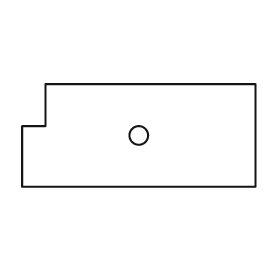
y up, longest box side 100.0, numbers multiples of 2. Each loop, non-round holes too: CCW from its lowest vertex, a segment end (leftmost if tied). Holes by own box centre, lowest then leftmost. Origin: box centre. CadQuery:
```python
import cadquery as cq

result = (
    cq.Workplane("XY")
    .moveTo(-50.0, -22.0)
    .lineTo(50.0, -22.0)
    .lineTo(50.0, 22.0)
    .lineTo(-40.0, 22.0)
    .lineTo(-40.0, 4.0)
    .lineTo(-50.0, 4.0)
    .close()
    .moveTo(0.0, 0.0)
    .circle(4.0)
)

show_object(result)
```